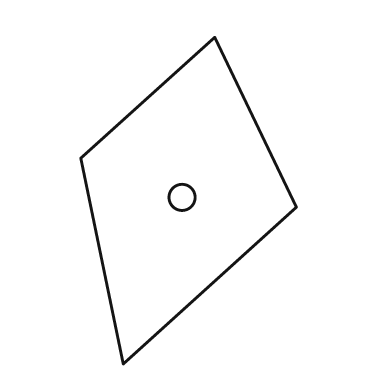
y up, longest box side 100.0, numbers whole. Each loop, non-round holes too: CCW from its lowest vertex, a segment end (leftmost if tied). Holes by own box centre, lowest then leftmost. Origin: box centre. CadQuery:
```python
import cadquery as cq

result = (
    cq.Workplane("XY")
    .moveTo(-20.0, -50.0)
    .lineTo(33.0, -2.0)
    .lineTo(8.0, 50.0)
    .lineTo(-33.0, 13.0)
    .close()
    .moveTo(-2.0, 1.0)
    .circle(4.0)
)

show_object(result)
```